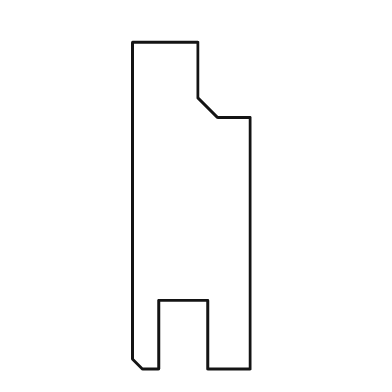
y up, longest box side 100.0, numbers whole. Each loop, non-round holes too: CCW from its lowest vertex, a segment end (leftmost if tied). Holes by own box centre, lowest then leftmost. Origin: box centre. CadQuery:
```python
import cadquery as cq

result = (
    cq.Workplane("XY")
    .moveTo(-15.0, -50.0)
    .lineTo(-10.0, -50.0)
    .lineTo(-10.0, -29.0)
    .lineTo(5.0, -29.0)
    .lineTo(5.0, -50.0)
    .lineTo(18.0, -50.0)
    .lineTo(18.0, 27.0)
    .lineTo(8.0, 27.0)
    .lineTo(2.0, 33.0)
    .lineTo(2.0, 50.0)
    .lineTo(-18.0, 50.0)
    .lineTo(-18.0, -47.0)
    .close()
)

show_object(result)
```